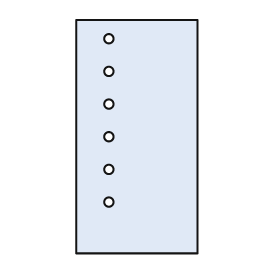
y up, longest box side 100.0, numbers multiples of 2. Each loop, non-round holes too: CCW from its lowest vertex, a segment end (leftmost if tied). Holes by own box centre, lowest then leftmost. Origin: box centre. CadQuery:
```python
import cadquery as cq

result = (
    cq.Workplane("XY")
    .moveTo(-26.0, -50.0)
    .lineTo(26.0, -50.0)
    .lineTo(26.0, 50.0)
    .lineTo(-26.0, 50.0)
    .close()
    .moveTo(-12.0, -28.0)
    .circle(2.0)
    .moveTo(-12.0, -14.0)
    .circle(2.0)
    .moveTo(-12.0, 0.0)
    .circle(2.0)
    .moveTo(-12.0, 14.0)
    .circle(2.0)
    .moveTo(-12.0, 28.0)
    .circle(2.0)
    .moveTo(-12.0, 42.0)
    .circle(2.0)
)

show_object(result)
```